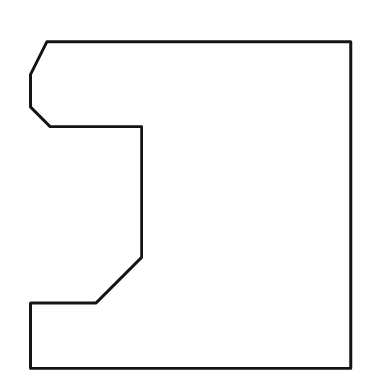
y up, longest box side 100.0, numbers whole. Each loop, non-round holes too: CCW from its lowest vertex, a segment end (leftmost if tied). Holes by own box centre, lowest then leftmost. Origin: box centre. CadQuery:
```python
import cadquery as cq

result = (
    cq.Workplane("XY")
    .moveTo(-49.0, -50.0)
    .lineTo(49.0, -50.0)
    .lineTo(49.0, 50.0)
    .lineTo(-44.0, 50.0)
    .lineTo(-49.0, 40.0)
    .lineTo(-49.0, 30.0)
    .lineTo(-43.0, 24.0)
    .lineTo(-15.0, 24.0)
    .lineTo(-15.0, -16.0)
    .lineTo(-29.0, -30.0)
    .lineTo(-49.0, -30.0)
    .close()
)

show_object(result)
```